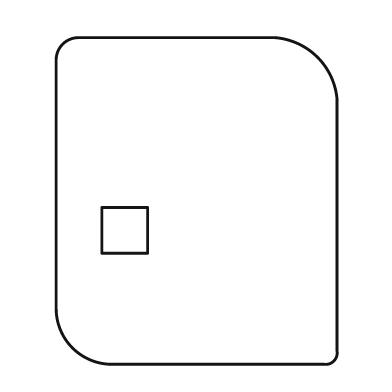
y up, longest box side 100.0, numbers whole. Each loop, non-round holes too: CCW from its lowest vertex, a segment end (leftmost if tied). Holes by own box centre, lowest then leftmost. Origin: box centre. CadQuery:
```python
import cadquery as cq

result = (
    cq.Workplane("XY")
    .moveTo(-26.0, -50.0)
    .lineTo(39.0, -50.0)
    .threePointArc((42.0, -49.0), (43.0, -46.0))
    .lineTo(43.0, 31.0)
    .threePointArc((37.0, 44.0), (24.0, 50.0))
    .lineTo(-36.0, 50.0)
    .threePointArc((-41.0, 48.0), (-43.0, 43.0))
    .lineTo(-43.0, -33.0)
    .threePointArc((-38.0, -45.0), (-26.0, -50.0))
    .close()
    .moveTo(-29.0, -16.0)
    .lineTo(-15.0, -16.0)
    .lineTo(-15.0, -2.0)
    .lineTo(-29.0, -2.0)
    .close()
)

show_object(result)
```